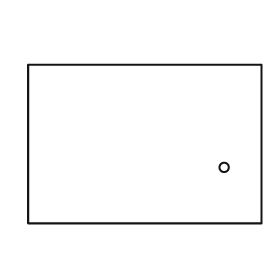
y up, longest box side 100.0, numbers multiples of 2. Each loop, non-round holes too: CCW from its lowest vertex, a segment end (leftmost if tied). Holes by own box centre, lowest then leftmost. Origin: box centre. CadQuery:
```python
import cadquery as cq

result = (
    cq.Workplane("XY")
    .moveTo(-50.0, -34.0)
    .lineTo(50.0, -34.0)
    .lineTo(50.0, 34.0)
    .lineTo(-50.0, 34.0)
    .close()
    .moveTo(34.0, -10.0)
    .circle(2.0)
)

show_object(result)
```